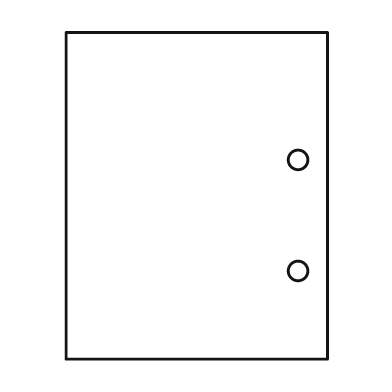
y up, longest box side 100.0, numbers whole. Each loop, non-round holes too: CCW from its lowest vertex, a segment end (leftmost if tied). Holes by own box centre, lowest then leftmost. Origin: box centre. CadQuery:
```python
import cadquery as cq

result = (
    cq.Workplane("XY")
    .moveTo(-40.0, -50.0)
    .lineTo(40.0, -50.0)
    .lineTo(40.0, 50.0)
    .lineTo(-40.0, 50.0)
    .close()
    .moveTo(31.0, -23.0)
    .circle(3.0)
    .moveTo(31.0, 11.0)
    .circle(3.0)
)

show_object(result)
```